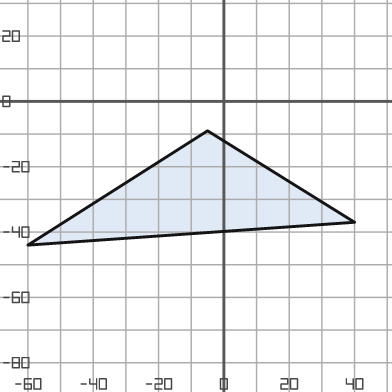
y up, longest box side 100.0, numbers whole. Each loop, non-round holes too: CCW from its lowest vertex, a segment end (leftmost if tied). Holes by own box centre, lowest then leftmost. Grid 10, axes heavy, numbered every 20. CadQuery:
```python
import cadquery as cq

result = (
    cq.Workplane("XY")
    .moveTo(-60.0, -44.0)
    .lineTo(40.0, -37.0)
    .lineTo(-5.0, -9.0)
    .close()
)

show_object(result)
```